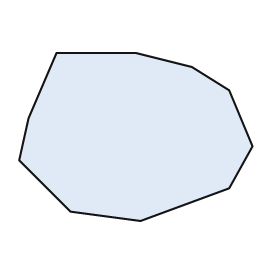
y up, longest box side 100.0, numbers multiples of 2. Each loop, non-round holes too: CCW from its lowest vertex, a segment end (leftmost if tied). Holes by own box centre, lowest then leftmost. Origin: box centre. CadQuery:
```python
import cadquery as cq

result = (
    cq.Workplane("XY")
    .moveTo(2.0, -36.0)
    .lineTo(40.0, -22.0)
    .lineTo(50.0, -4.0)
    .lineTo(40.0, 20.0)
    .lineTo(24.0, 30.0)
    .lineTo(0.0, 36.0)
    .lineTo(-34.0, 36.0)
    .lineTo(-46.0, 8.0)
    .lineTo(-50.0, -10.0)
    .lineTo(-28.0, -32.0)
    .close()
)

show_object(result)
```